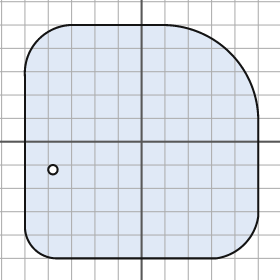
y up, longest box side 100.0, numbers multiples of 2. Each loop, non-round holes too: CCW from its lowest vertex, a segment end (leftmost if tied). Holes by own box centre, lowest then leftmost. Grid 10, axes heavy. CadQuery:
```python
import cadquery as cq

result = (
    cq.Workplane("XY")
    .moveTo(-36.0, -50.0)
    .lineTo(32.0, -50.0)
    .threePointArc((44.0, -44.0), (50.0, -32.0))
    .lineTo(50.0, 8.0)
    .threePointArc((38.0, 38.0), (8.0, 50.0))
    .lineTo(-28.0, 50.0)
    .threePointArc((-44.0, 44.0), (-50.0, 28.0))
    .lineTo(-50.0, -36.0)
    .threePointArc((-46.0, -46.0), (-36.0, -50.0))
    .close()
    .moveTo(-38.0, -12.0)
    .circle(2.0)
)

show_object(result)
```